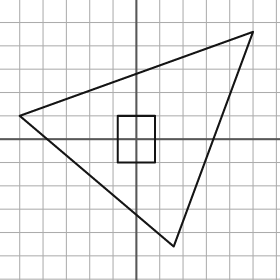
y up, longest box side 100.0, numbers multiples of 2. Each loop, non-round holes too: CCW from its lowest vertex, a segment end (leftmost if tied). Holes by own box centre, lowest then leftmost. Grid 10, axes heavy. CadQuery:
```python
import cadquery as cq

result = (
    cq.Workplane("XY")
    .moveTo(16.0, -46.0)
    .lineTo(50.0, 46.0)
    .lineTo(-50.0, 10.0)
    .close()
    .moveTo(-8.0, -10.0)
    .lineTo(8.0, -10.0)
    .lineTo(8.0, 10.0)
    .lineTo(-8.0, 10.0)
    .close()
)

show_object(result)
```